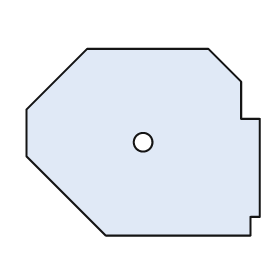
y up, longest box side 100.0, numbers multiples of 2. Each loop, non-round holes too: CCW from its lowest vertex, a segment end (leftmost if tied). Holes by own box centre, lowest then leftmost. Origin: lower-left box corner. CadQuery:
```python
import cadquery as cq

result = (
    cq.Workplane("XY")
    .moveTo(34.0, 0.0)
    .lineTo(96.0, 0.0)
    .lineTo(96.0, 8.0)
    .lineTo(100.0, 8.0)
    .lineTo(100.0, 50.0)
    .lineTo(92.0, 50.0)
    .lineTo(92.0, 66.0)
    .lineTo(78.0, 80.0)
    .lineTo(26.0, 80.0)
    .lineTo(0.0, 54.0)
    .lineTo(0.0, 34.0)
    .close()
    .moveTo(50.0, 40.0)
    .circle(4.0)
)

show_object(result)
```